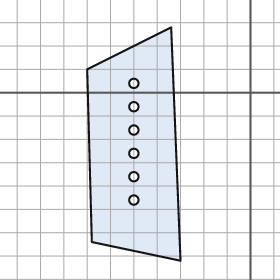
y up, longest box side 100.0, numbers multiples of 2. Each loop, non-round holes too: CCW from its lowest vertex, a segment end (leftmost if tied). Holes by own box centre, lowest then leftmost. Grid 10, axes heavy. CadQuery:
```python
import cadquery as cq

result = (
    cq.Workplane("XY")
    .moveTo(-30.0, -72.0)
    .lineTo(-34.0, 28.0)
    .lineTo(-70.0, 10.0)
    .lineTo(-68.0, -64.0)
    .close()
    .moveTo(-50.0, -46.0)
    .circle(2.0)
    .moveTo(-50.0, -36.0)
    .circle(2.0)
    .moveTo(-50.0, -26.0)
    .circle(2.0)
    .moveTo(-50.0, -16.0)
    .circle(2.0)
    .moveTo(-50.0, -6.0)
    .circle(2.0)
    .moveTo(-50.0, 4.0)
    .circle(2.0)
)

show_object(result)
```